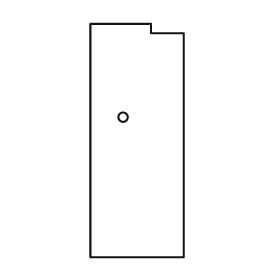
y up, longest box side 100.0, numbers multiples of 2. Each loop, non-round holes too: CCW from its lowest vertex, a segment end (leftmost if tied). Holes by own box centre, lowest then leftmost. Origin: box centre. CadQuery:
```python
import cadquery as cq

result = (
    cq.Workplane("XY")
    .moveTo(-20.0, -50.0)
    .lineTo(20.0, -50.0)
    .lineTo(20.0, 46.0)
    .lineTo(6.0, 46.0)
    .lineTo(6.0, 50.0)
    .lineTo(-20.0, 50.0)
    .close()
    .moveTo(-6.0, 10.0)
    .circle(2.0)
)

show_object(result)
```